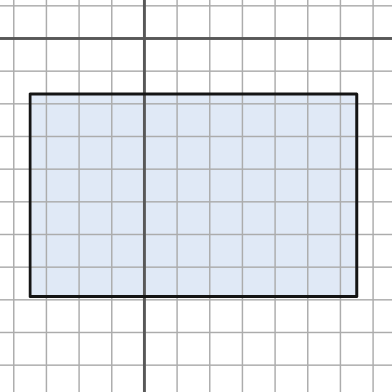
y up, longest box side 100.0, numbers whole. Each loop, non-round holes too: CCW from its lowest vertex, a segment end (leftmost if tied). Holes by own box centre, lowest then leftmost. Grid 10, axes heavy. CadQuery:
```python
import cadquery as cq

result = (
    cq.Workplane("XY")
    .moveTo(-35.0, -79.0)
    .lineTo(65.0, -79.0)
    .lineTo(65.0, -17.0)
    .lineTo(-35.0, -17.0)
    .close()
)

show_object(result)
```